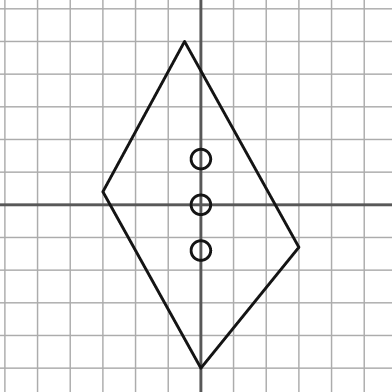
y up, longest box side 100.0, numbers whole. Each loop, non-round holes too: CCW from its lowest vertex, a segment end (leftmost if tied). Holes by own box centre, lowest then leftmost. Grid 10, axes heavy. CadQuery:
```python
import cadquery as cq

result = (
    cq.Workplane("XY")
    .moveTo(0.0, -50.0)
    .lineTo(30.0, -13.0)
    .lineTo(-5.0, 50.0)
    .lineTo(-30.0, 4.0)
    .close()
    .moveTo(0.0, -14.0)
    .circle(3.0)
    .moveTo(0.0, 0.0)
    .circle(3.0)
    .moveTo(0.0, 14.0)
    .circle(3.0)
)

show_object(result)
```